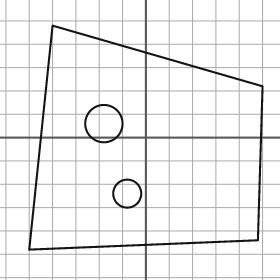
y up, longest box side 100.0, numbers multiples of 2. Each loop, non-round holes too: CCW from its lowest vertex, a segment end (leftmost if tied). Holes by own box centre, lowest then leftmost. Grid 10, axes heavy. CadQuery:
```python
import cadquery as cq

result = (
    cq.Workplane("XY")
    .moveTo(-50.0, -48.0)
    .lineTo(48.0, -44.0)
    .lineTo(50.0, 22.0)
    .lineTo(-40.0, 48.0)
    .close()
    .moveTo(-8.0, -24.0)
    .circle(6.0)
    .moveTo(-18.0, 6.0)
    .circle(8.0)
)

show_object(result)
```